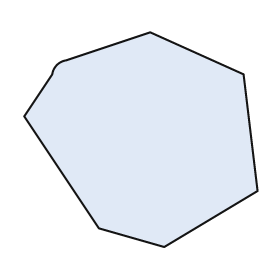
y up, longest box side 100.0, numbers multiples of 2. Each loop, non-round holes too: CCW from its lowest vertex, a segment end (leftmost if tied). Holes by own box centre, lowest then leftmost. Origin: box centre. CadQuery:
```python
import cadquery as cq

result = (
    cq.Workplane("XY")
    .moveTo(10.0, -46.0)
    .lineTo(50.0, -22.0)
    .lineTo(44.0, 28.0)
    .lineTo(4.0, 46.0)
    .lineTo(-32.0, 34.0)
    .threePointArc((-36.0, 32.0), (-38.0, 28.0))
    .lineTo(-50.0, 10.0)
    .lineTo(-18.0, -38.0)
    .close()
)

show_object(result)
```